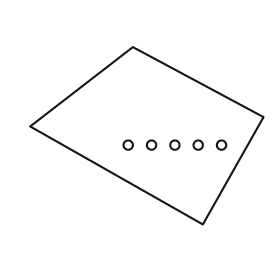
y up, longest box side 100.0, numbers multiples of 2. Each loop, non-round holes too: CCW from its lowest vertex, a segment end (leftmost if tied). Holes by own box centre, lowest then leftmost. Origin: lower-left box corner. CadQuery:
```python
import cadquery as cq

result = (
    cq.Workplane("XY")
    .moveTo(74.0, 0.0)
    .lineTo(100.0, 46.0)
    .lineTo(44.0, 76.0)
    .lineTo(0.0, 42.0)
    .close()
    .moveTo(42.0, 34.0)
    .circle(2.0)
    .moveTo(52.0, 34.0)
    .circle(2.0)
    .moveTo(62.0, 34.0)
    .circle(2.0)
    .moveTo(72.0, 34.0)
    .circle(2.0)
    .moveTo(82.0, 34.0)
    .circle(2.0)
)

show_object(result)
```